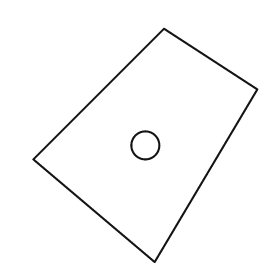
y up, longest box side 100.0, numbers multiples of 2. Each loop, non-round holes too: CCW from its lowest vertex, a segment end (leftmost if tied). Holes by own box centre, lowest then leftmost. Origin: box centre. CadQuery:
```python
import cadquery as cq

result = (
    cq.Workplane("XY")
    .moveTo(4.0, -50.0)
    .lineTo(48.0, 24.0)
    .lineTo(8.0, 50.0)
    .lineTo(-48.0, -6.0)
    .close()
    .moveTo(0.0, 0.0)
    .circle(6.0)
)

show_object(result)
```